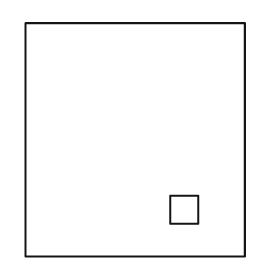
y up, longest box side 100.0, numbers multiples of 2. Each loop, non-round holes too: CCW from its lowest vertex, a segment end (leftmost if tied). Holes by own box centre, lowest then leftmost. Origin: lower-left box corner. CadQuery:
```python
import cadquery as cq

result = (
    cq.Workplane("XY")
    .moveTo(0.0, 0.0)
    .lineTo(94.0, 0.0)
    .lineTo(94.0, 100.0)
    .lineTo(0.0, 100.0)
    .close()
    .moveTo(62.0, 14.0)
    .lineTo(74.0, 14.0)
    .lineTo(74.0, 26.0)
    .lineTo(62.0, 26.0)
    .close()
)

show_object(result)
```